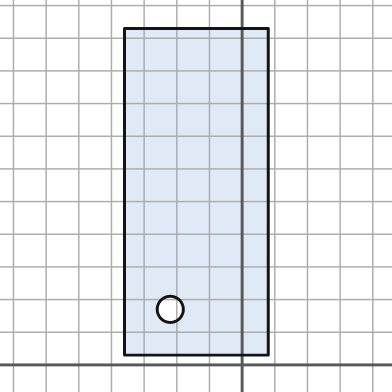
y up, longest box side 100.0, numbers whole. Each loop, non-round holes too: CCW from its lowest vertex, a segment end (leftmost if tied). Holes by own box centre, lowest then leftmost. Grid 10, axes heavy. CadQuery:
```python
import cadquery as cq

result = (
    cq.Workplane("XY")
    .moveTo(-36.0, 3.0)
    .lineTo(8.0, 3.0)
    .lineTo(8.0, 103.0)
    .lineTo(-36.0, 103.0)
    .close()
    .moveTo(-22.0, 17.0)
    .circle(4.0)
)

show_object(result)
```